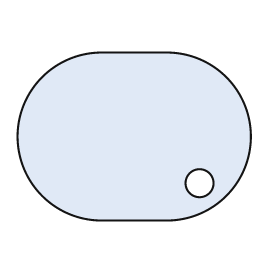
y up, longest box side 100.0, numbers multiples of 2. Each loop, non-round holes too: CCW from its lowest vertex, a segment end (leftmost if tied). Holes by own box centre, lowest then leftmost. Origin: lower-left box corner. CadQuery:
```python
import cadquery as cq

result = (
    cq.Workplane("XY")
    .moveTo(36.0, 0.0)
    .lineTo(64.0, 0.0)
    .threePointArc((100.0, 36.0), (64.0, 72.0))
    .lineTo(36.0, 72.0)
    .threePointArc((0.0, 36.0), (36.0, 0.0))
    .close()
    .moveTo(78.0, 16.0)
    .circle(6.0)
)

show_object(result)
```